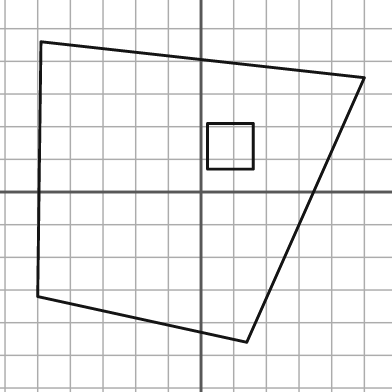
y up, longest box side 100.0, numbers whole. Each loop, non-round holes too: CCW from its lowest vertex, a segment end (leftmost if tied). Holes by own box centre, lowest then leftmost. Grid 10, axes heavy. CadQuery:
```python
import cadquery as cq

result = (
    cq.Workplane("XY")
    .moveTo(14.0, -46.0)
    .lineTo(50.0, 35.0)
    .lineTo(-49.0, 46.0)
    .lineTo(-50.0, -32.0)
    .close()
    .moveTo(2.0, 7.0)
    .lineTo(16.0, 7.0)
    .lineTo(16.0, 21.0)
    .lineTo(2.0, 21.0)
    .close()
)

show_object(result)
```